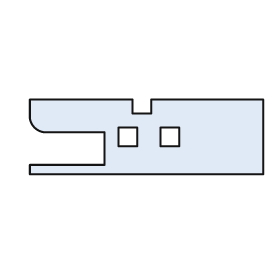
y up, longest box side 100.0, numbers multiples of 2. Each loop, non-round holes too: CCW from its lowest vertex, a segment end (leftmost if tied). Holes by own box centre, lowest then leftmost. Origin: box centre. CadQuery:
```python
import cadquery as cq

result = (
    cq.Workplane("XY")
    .moveTo(-50.0, -16.0)
    .lineTo(50.0, -16.0)
    .lineTo(50.0, 16.0)
    .lineTo(2.0, 16.0)
    .lineTo(2.0, 10.0)
    .lineTo(-6.0, 10.0)
    .lineTo(-6.0, 16.0)
    .lineTo(-50.0, 16.0)
    .lineTo(-50.0, 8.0)
    .threePointArc((-48.0, 4.0), (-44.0, 2.0))
    .lineTo(-18.0, 2.0)
    .lineTo(-18.0, -12.0)
    .lineTo(-50.0, -12.0)
    .close()
    .moveTo(-12.0, -4.0)
    .lineTo(-4.0, -4.0)
    .lineTo(-4.0, 4.0)
    .lineTo(-12.0, 4.0)
    .close()
    .moveTo(6.0, -4.0)
    .lineTo(14.0, -4.0)
    .lineTo(14.0, 4.0)
    .lineTo(6.0, 4.0)
    .close()
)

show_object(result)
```